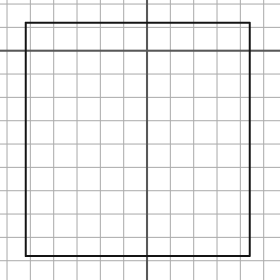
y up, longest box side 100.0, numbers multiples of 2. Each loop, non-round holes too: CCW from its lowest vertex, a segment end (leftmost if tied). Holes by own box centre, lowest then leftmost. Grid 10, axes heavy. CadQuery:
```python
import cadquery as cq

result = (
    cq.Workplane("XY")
    .moveTo(-52.0, -88.0)
    .lineTo(44.0, -88.0)
    .lineTo(44.0, 12.0)
    .lineTo(-52.0, 12.0)
    .close()
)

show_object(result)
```